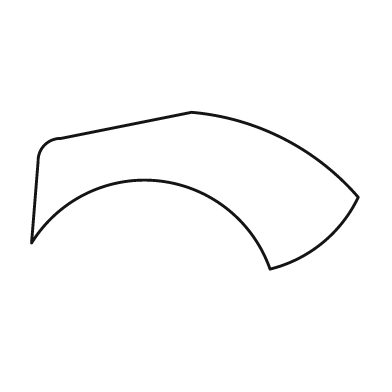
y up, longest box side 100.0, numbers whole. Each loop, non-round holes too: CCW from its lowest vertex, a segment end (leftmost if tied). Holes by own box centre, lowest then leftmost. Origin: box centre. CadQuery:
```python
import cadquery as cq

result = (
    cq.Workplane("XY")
    .moveTo(23.0, -24.0)
    .threePointArc((39.0, -16.0), (50.0, -2.0))
    .threePointArc((27.0, 16.0), (-1.0, 24.0))
    .lineTo(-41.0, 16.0)
    .threePointArc((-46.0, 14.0), (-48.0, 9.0))
    .lineTo(-50.0, -16.0)
    .threePointArc((-11.0, 3.0), (23.0, -24.0))
    .close()
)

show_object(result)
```